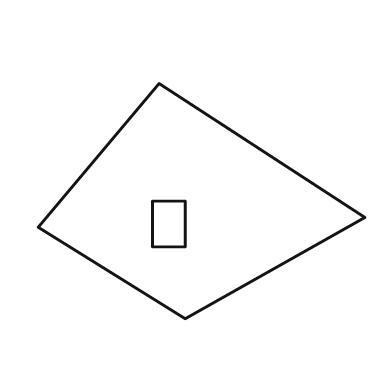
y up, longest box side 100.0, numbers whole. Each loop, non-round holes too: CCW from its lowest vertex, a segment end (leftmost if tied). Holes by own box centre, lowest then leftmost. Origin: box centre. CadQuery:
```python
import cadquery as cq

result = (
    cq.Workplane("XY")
    .moveTo(-5.0, -36.0)
    .lineTo(50.0, -5.0)
    .lineTo(-13.0, 36.0)
    .lineTo(-50.0, -8.0)
    .close()
    .moveTo(-15.0, -14.0)
    .lineTo(-5.0, -14.0)
    .lineTo(-5.0, 0.0)
    .lineTo(-15.0, 0.0)
    .close()
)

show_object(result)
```